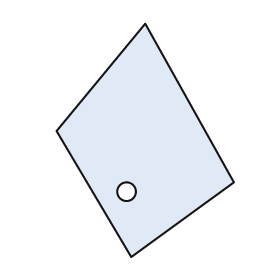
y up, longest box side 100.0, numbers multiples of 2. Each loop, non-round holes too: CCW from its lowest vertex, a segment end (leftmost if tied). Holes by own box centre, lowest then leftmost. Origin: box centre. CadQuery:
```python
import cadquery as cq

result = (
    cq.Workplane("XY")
    .moveTo(-6.0, -50.0)
    .lineTo(38.0, -18.0)
    .lineTo(0.0, 50.0)
    .lineTo(-38.0, 4.0)
    .close()
    .moveTo(-8.0, -22.0)
    .circle(4.0)
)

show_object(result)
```